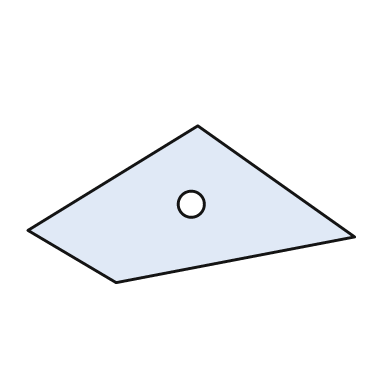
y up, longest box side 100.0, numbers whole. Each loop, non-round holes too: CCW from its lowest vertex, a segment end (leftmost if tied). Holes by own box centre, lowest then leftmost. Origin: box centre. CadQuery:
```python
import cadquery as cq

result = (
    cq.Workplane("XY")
    .moveTo(-23.0, -24.0)
    .lineTo(50.0, -10.0)
    .lineTo(2.0, 24.0)
    .lineTo(-50.0, -8.0)
    .close()
    .moveTo(0.0, 0.0)
    .circle(4.0)
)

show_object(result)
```